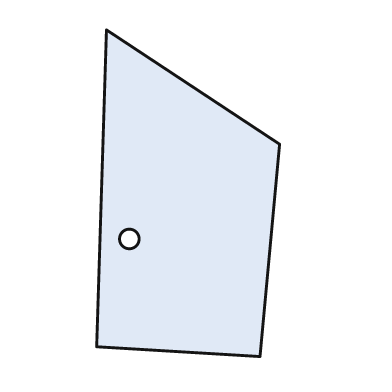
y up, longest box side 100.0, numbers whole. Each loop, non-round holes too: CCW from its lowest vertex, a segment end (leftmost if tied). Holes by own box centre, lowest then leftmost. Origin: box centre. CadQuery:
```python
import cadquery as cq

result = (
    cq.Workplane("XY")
    .moveTo(22.0, -50.0)
    .lineTo(28.0, 15.0)
    .lineTo(-25.0, 50.0)
    .lineTo(-28.0, -47.0)
    .close()
    .moveTo(-18.0, -14.0)
    .circle(3.0)
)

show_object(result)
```